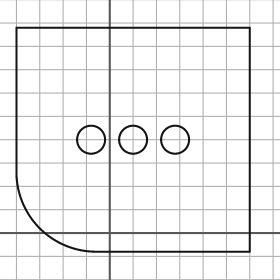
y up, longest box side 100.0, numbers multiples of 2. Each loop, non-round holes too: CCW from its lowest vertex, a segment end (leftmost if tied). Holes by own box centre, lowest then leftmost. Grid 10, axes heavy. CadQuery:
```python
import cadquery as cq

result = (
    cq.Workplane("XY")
    .moveTo(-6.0, -8.0)
    .lineTo(60.0, -8.0)
    .lineTo(60.0, 88.0)
    .lineTo(-40.0, 88.0)
    .lineTo(-40.0, 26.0)
    .threePointArc((-30.0, 2.0), (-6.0, -8.0))
    .close()
    .moveTo(-8.0, 40.0)
    .circle(6.0)
    .moveTo(10.0, 40.0)
    .circle(6.0)
    .moveTo(28.0, 40.0)
    .circle(6.0)
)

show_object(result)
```